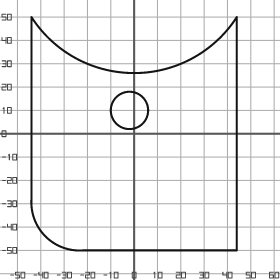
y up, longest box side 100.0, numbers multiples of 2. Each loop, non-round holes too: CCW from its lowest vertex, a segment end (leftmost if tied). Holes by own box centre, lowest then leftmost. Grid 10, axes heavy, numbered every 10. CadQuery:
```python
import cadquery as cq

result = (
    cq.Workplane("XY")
    .moveTo(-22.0, -50.0)
    .lineTo(44.0, -50.0)
    .lineTo(44.0, 50.0)
    .threePointArc((0.0, 26.0), (-44.0, 50.0))
    .lineTo(-44.0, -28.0)
    .threePointArc((-38.0, -44.0), (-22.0, -50.0))
    .close()
    .moveTo(-2.0, 10.0)
    .circle(8.0)
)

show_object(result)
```